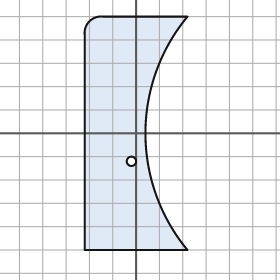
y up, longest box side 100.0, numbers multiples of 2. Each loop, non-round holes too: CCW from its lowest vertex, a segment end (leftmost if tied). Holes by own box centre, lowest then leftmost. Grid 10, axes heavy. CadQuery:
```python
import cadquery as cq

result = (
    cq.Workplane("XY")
    .moveTo(-22.0, -50.0)
    .lineTo(22.0, -50.0)
    .threePointArc((4.0, 0.0), (22.0, 50.0))
    .lineTo(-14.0, 50.0)
    .threePointArc((-20.0, 48.0), (-22.0, 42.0))
    .close()
    .moveTo(-2.0, -12.0)
    .circle(2.0)
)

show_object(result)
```